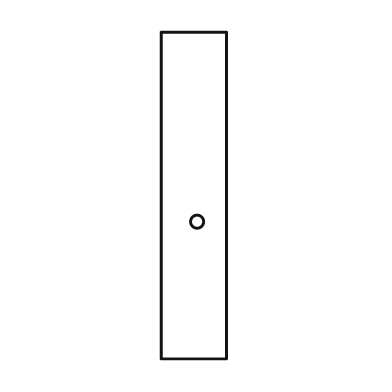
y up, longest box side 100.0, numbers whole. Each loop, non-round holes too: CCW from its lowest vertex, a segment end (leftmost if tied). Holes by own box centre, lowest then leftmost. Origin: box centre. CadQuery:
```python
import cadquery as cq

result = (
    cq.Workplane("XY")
    .moveTo(-10.0, -50.0)
    .lineTo(10.0, -50.0)
    .lineTo(10.0, 50.0)
    .lineTo(-10.0, 50.0)
    .close()
    .moveTo(1.0, -8.0)
    .circle(2.0)
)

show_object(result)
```